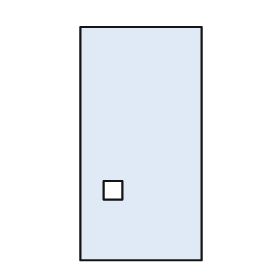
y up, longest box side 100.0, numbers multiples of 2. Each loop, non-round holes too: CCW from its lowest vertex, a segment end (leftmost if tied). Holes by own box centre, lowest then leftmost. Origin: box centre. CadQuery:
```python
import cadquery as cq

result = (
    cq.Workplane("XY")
    .moveTo(-26.0, -50.0)
    .lineTo(26.0, -50.0)
    .lineTo(26.0, 50.0)
    .lineTo(-26.0, 50.0)
    .close()
    .moveTo(-16.0, -24.0)
    .lineTo(-8.0, -24.0)
    .lineTo(-8.0, -16.0)
    .lineTo(-16.0, -16.0)
    .close()
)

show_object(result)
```